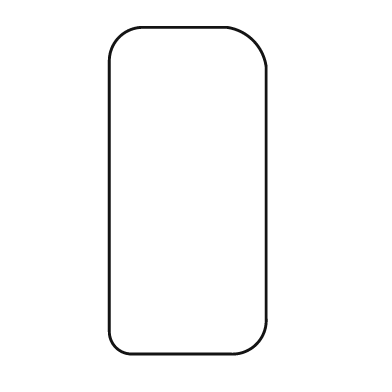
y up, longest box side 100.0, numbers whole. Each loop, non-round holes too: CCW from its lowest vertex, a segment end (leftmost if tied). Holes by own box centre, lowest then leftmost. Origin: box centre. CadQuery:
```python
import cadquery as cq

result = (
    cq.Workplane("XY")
    .moveTo(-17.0, -50.0)
    .lineTo(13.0, -50.0)
    .threePointArc((21.0, -47.0), (24.0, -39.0))
    .lineTo(24.0, 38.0)
    .threePointArc((20.0, 46.0), (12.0, 50.0))
    .lineTo(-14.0, 50.0)
    .threePointArc((-21.0, 47.0), (-24.0, 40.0))
    .lineTo(-24.0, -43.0)
    .threePointArc((-22.0, -48.0), (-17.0, -50.0))
    .close()
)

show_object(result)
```